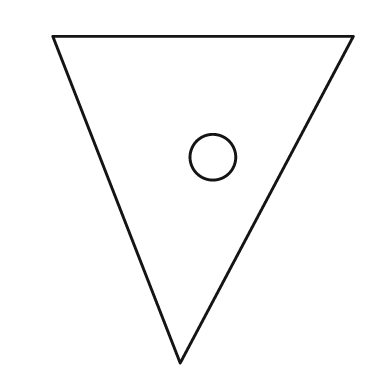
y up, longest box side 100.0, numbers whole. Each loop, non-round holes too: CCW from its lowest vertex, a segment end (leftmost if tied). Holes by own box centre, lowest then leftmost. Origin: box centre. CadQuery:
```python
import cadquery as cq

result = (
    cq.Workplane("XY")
    .moveTo(-7.0, -50.0)
    .lineTo(46.0, 50.0)
    .lineTo(-46.0, 50.0)
    .close()
    .moveTo(3.0, 13.0)
    .circle(7.0)
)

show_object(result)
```